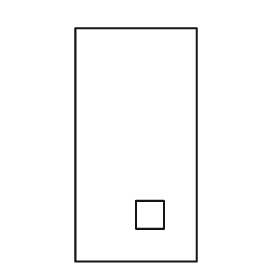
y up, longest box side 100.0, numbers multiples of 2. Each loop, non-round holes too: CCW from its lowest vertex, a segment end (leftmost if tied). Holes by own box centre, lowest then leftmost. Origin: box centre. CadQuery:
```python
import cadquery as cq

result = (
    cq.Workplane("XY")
    .moveTo(-26.0, -50.0)
    .lineTo(26.0, -50.0)
    .lineTo(26.0, 50.0)
    .lineTo(-26.0, 50.0)
    .close()
    .moveTo(0.0, -36.0)
    .lineTo(12.0, -36.0)
    .lineTo(12.0, -24.0)
    .lineTo(0.0, -24.0)
    .close()
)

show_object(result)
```